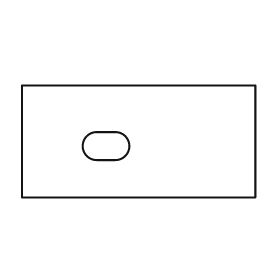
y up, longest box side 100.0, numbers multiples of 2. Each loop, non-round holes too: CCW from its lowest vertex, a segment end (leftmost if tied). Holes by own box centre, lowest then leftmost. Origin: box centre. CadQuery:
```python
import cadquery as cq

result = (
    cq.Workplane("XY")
    .moveTo(-50.0, -24.0)
    .lineTo(50.0, -24.0)
    .lineTo(50.0, 24.0)
    .lineTo(-50.0, 24.0)
    .close()
    .moveTo(-18.0, -8.0)
    .lineTo(-10.0, -8.0)
    .threePointArc((-4.0, -2.0), (-10.0, 4.0))
    .lineTo(-18.0, 4.0)
    .threePointArc((-24.0, -2.0), (-18.0, -8.0))
    .close()
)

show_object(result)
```